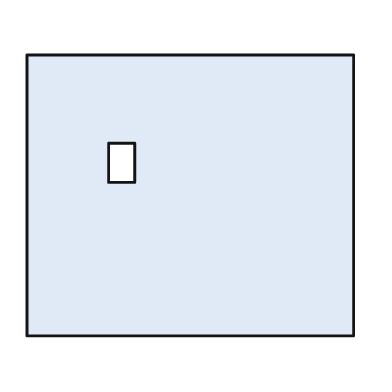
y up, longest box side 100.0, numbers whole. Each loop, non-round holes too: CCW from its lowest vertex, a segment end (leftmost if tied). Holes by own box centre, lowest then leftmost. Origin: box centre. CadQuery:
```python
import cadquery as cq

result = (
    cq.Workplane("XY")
    .moveTo(-50.0, -43.0)
    .lineTo(50.0, -43.0)
    .lineTo(50.0, 43.0)
    .lineTo(-50.0, 43.0)
    .close()
    .moveTo(-25.0, 4.0)
    .lineTo(-17.0, 4.0)
    .lineTo(-17.0, 16.0)
    .lineTo(-25.0, 16.0)
    .close()
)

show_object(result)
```